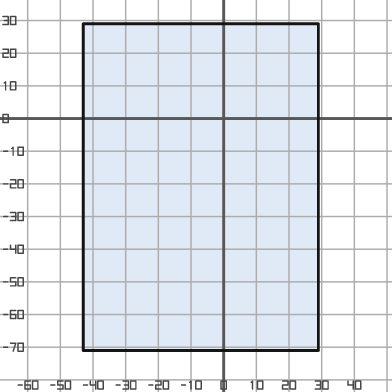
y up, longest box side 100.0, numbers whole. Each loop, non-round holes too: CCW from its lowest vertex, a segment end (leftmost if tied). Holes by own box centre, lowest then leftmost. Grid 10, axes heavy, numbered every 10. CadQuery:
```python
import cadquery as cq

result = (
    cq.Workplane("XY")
    .moveTo(-43.0, -71.0)
    .lineTo(29.0, -71.0)
    .lineTo(29.0, 29.0)
    .lineTo(-43.0, 29.0)
    .close()
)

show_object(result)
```